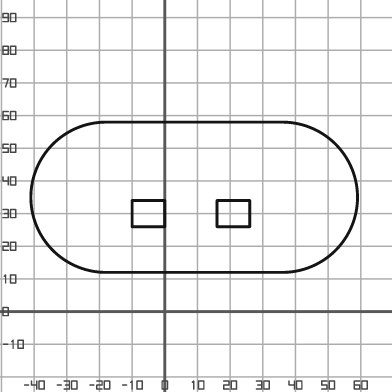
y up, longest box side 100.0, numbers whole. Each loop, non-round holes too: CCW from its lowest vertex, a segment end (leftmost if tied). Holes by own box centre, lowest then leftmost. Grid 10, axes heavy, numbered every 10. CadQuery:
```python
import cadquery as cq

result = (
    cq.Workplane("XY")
    .moveTo(-18.0, 12.0)
    .lineTo(36.0, 12.0)
    .threePointArc((59.0, 35.0), (36.0, 58.0))
    .lineTo(-18.0, 58.0)
    .threePointArc((-41.0, 35.0), (-18.0, 12.0))
    .close()
    .moveTo(-10.0, 26.0)
    .lineTo(0.0, 26.0)
    .lineTo(0.0, 34.0)
    .lineTo(-10.0, 34.0)
    .close()
    .moveTo(16.0, 26.0)
    .lineTo(26.0, 26.0)
    .lineTo(26.0, 34.0)
    .lineTo(16.0, 34.0)
    .close()
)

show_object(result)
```